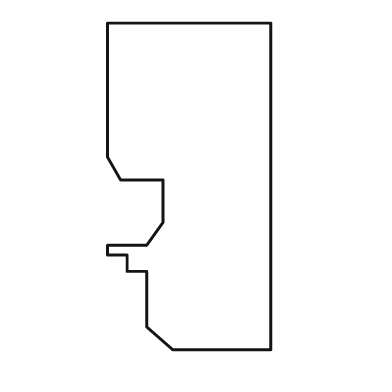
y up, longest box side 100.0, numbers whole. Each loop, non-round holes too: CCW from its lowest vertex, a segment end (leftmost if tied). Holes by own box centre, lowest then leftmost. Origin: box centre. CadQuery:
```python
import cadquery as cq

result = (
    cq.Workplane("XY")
    .moveTo(-5.0, -50.0)
    .lineTo(25.0, -50.0)
    .lineTo(25.0, 50.0)
    .lineTo(-25.0, 50.0)
    .lineTo(-25.0, 9.0)
    .lineTo(-21.0, 2.0)
    .lineTo(-8.0, 2.0)
    .lineTo(-8.0, -11.0)
    .lineTo(-13.0, -18.0)
    .lineTo(-25.0, -18.0)
    .lineTo(-25.0, -21.0)
    .lineTo(-19.0, -21.0)
    .lineTo(-19.0, -26.0)
    .lineTo(-13.0, -26.0)
    .lineTo(-13.0, -43.0)
    .close()
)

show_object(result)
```